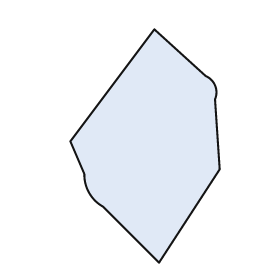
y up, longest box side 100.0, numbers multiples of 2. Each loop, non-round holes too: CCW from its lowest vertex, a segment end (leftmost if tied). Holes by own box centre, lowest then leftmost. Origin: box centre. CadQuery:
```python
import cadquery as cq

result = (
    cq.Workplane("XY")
    .moveTo(6.0, -50.0)
    .lineTo(32.0, -10.0)
    .lineTo(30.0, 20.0)
    .threePointArc((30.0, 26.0), (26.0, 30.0))
    .lineTo(4.0, 50.0)
    .lineTo(-32.0, 2.0)
    .lineTo(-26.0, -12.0)
    .threePointArc((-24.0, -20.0), (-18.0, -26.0))
    .close()
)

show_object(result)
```